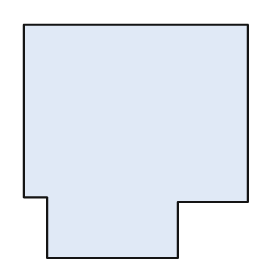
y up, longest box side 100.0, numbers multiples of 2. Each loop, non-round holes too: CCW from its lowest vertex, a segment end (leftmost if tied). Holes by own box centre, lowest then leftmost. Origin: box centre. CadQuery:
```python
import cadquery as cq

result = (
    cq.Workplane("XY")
    .moveTo(-38.0, -50.0)
    .lineTo(18.0, -50.0)
    .lineTo(18.0, -26.0)
    .lineTo(48.0, -26.0)
    .lineTo(48.0, 50.0)
    .lineTo(-48.0, 50.0)
    .lineTo(-48.0, -24.0)
    .lineTo(-38.0, -24.0)
    .close()
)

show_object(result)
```